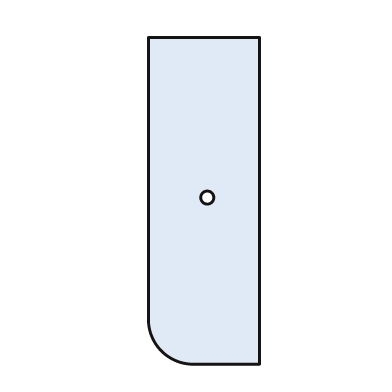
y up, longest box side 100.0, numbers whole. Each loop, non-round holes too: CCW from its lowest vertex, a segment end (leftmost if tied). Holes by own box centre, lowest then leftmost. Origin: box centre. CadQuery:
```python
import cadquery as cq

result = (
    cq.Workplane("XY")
    .moveTo(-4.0, -50.0)
    .lineTo(17.0, -50.0)
    .lineTo(17.0, 50.0)
    .lineTo(-17.0, 50.0)
    .lineTo(-17.0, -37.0)
    .threePointArc((-13.0, -46.0), (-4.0, -50.0))
    .close()
    .moveTo(1.0, 1.0)
    .circle(2.0)
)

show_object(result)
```